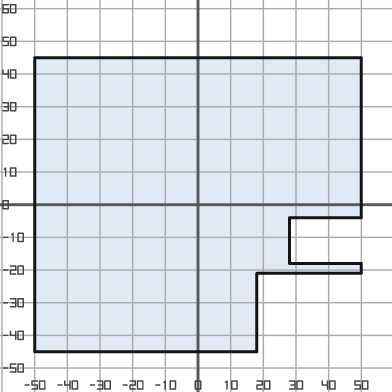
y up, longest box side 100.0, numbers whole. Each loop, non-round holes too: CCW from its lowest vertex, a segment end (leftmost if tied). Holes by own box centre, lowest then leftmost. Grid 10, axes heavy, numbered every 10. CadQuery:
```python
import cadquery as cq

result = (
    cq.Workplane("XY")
    .moveTo(-50.0, -45.0)
    .lineTo(18.0, -45.0)
    .lineTo(18.0, -21.0)
    .lineTo(50.0, -21.0)
    .lineTo(50.0, -18.0)
    .lineTo(28.0, -18.0)
    .lineTo(28.0, -4.0)
    .lineTo(50.0, -4.0)
    .lineTo(50.0, 45.0)
    .lineTo(-50.0, 45.0)
    .close()
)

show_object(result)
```